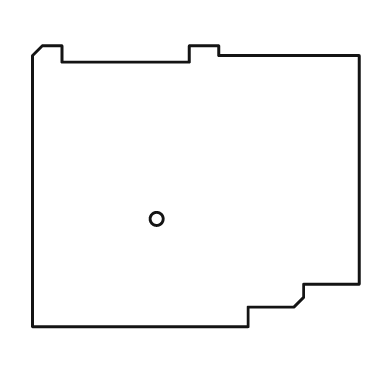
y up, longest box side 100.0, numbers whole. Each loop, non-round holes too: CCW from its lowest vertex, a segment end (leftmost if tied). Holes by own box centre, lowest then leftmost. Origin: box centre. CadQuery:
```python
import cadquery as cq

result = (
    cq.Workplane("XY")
    .moveTo(-50.0, -43.0)
    .lineTo(16.0, -43.0)
    .lineTo(16.0, -37.0)
    .lineTo(30.0, -37.0)
    .lineTo(33.0, -34.0)
    .lineTo(33.0, -30.0)
    .lineTo(50.0, -30.0)
    .lineTo(50.0, 40.0)
    .lineTo(7.0, 40.0)
    .lineTo(7.0, 43.0)
    .lineTo(-2.0, 43.0)
    .lineTo(-2.0, 38.0)
    .lineTo(-41.0, 38.0)
    .lineTo(-41.0, 43.0)
    .lineTo(-47.0, 43.0)
    .lineTo(-50.0, 40.0)
    .close()
    .moveTo(-12.0, -10.0)
    .circle(2.0)
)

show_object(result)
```